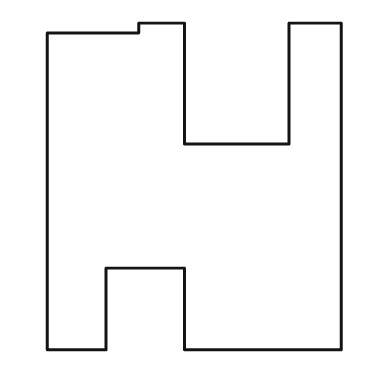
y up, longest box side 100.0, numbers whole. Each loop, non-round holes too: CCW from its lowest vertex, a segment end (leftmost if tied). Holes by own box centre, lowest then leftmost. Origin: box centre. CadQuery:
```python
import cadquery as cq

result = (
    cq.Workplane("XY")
    .moveTo(-45.0, -50.0)
    .lineTo(-27.0, -50.0)
    .lineTo(-27.0, -25.0)
    .lineTo(-3.0, -25.0)
    .lineTo(-3.0, -50.0)
    .lineTo(45.0, -50.0)
    .lineTo(45.0, 50.0)
    .lineTo(29.0, 50.0)
    .lineTo(29.0, 13.0)
    .lineTo(-3.0, 13.0)
    .lineTo(-3.0, 50.0)
    .lineTo(-17.0, 50.0)
    .lineTo(-17.0, 47.0)
    .lineTo(-45.0, 47.0)
    .close()
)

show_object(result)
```